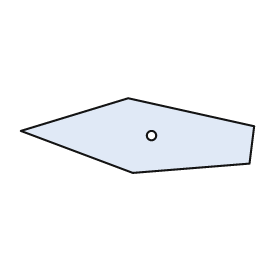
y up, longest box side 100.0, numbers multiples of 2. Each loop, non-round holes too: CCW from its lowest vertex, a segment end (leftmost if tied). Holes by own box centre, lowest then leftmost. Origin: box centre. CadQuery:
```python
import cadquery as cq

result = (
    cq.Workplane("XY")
    .moveTo(-2.0, -16.0)
    .lineTo(48.0, -12.0)
    .lineTo(50.0, 4.0)
    .lineTo(-4.0, 16.0)
    .lineTo(-50.0, 2.0)
    .close()
    .moveTo(6.0, 0.0)
    .circle(2.0)
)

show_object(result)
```